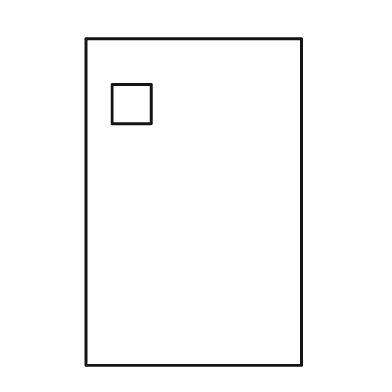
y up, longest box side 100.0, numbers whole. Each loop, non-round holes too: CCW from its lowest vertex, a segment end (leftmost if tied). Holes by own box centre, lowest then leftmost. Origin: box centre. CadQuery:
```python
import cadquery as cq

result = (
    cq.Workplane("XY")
    .moveTo(-33.0, -50.0)
    .lineTo(33.0, -50.0)
    .lineTo(33.0, 50.0)
    .lineTo(-33.0, 50.0)
    .close()
    .moveTo(-25.0, 24.0)
    .lineTo(-13.0, 24.0)
    .lineTo(-13.0, 36.0)
    .lineTo(-25.0, 36.0)
    .close()
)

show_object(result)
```